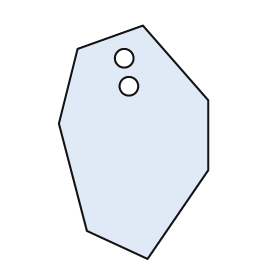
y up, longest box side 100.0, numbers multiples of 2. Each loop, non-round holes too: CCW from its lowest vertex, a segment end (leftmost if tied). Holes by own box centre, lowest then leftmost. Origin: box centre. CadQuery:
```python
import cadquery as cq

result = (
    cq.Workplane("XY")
    .moveTo(6.0, -50.0)
    .lineTo(32.0, -12.0)
    .lineTo(32.0, 18.0)
    .lineTo(4.0, 50.0)
    .lineTo(-24.0, 40.0)
    .lineTo(-32.0, 8.0)
    .lineTo(-20.0, -38.0)
    .close()
    .moveTo(-2.0, 24.0)
    .circle(4.0)
    .moveTo(-4.0, 36.0)
    .circle(4.0)
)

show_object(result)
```